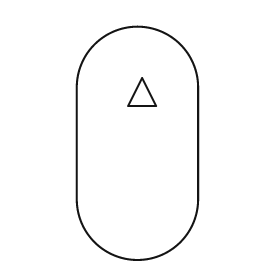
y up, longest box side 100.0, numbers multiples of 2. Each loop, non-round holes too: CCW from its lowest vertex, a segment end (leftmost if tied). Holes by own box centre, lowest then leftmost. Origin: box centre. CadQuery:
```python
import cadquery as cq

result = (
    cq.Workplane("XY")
    .moveTo(-26.0, -24.0)
    .threePointArc((0.0, -50.0), (26.0, -24.0))
    .lineTo(26.0, 24.0)
    .threePointArc((0.0, 50.0), (-26.0, 24.0))
    .close()
    .moveTo(-4.0, 16.0)
    .lineTo(8.0, 16.0)
    .lineTo(2.0, 28.0)
    .close()
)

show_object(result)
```